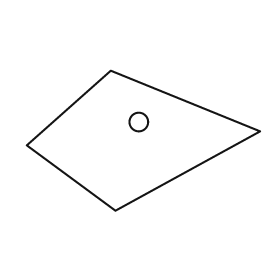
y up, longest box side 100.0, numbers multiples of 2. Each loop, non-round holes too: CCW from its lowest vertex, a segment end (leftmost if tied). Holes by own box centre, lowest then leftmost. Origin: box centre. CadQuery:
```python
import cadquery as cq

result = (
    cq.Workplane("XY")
    .moveTo(-12.0, -30.0)
    .lineTo(50.0, 4.0)
    .lineTo(-14.0, 30.0)
    .lineTo(-50.0, -2.0)
    .close()
    .moveTo(-2.0, 8.0)
    .circle(4.0)
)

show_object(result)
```